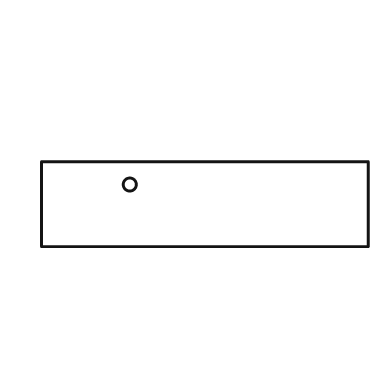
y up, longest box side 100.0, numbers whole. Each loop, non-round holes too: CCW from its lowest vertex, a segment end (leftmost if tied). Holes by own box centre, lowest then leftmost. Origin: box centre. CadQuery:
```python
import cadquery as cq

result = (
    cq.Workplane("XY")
    .moveTo(-50.0, -13.0)
    .lineTo(50.0, -13.0)
    .lineTo(50.0, 13.0)
    .lineTo(-50.0, 13.0)
    .close()
    .moveTo(-23.0, 6.0)
    .circle(2.0)
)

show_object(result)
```